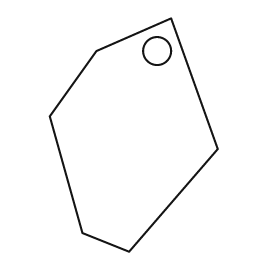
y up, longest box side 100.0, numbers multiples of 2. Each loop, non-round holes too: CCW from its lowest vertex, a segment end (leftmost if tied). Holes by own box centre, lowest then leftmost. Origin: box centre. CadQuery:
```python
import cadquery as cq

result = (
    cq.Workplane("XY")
    .moveTo(-2.0, -50.0)
    .lineTo(36.0, -6.0)
    .lineTo(16.0, 50.0)
    .lineTo(-16.0, 36.0)
    .lineTo(-36.0, 8.0)
    .lineTo(-22.0, -42.0)
    .close()
    .moveTo(10.0, 36.0)
    .circle(6.0)
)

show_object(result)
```